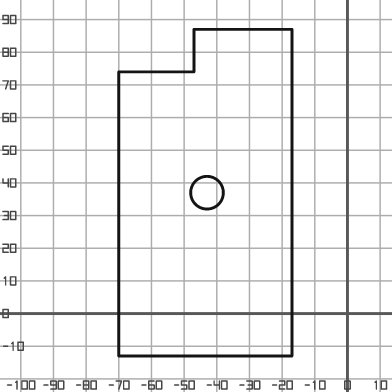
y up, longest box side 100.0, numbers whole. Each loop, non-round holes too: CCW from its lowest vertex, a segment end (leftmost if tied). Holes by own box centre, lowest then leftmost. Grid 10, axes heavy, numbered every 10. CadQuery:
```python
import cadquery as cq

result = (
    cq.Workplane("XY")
    .moveTo(-70.0, -13.0)
    .lineTo(-17.0, -13.0)
    .lineTo(-17.0, 87.0)
    .lineTo(-47.0, 87.0)
    .lineTo(-47.0, 74.0)
    .lineTo(-70.0, 74.0)
    .close()
    .moveTo(-43.0, 37.0)
    .circle(5.0)
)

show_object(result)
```